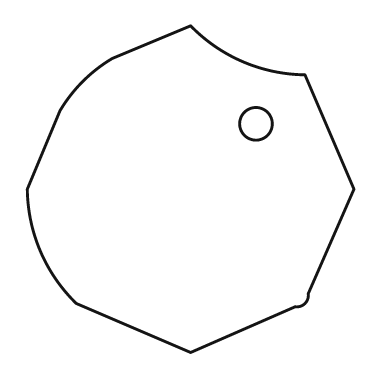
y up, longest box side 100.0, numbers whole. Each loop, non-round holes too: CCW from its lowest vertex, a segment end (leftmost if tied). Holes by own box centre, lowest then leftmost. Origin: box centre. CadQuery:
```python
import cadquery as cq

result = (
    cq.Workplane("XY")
    .moveTo(0.0, -50.0)
    .lineTo(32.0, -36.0)
    .threePointArc((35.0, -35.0), (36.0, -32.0))
    .lineTo(50.0, 0.0)
    .lineTo(35.0, 35.0)
    .threePointArc((16.0, 39.0), (0.0, 50.0))
    .lineTo(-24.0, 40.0)
    .threePointArc((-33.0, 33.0), (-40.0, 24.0))
    .lineTo(-50.0, 0.0)
    .threePointArc((-46.0, -19.0), (-35.0, -35.0))
    .close()
    .moveTo(20.0, 20.0)
    .circle(5.0)
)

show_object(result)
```